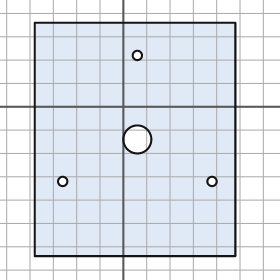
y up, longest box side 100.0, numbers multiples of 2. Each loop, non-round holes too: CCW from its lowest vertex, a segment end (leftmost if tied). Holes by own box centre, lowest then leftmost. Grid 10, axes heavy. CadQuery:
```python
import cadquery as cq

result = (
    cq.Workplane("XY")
    .moveTo(-38.0, -64.0)
    .lineTo(48.0, -64.0)
    .lineTo(48.0, 36.0)
    .lineTo(-38.0, 36.0)
    .close()
    .moveTo(-26.0, -32.0)
    .circle(2.0)
    .moveTo(38.0, -32.0)
    .circle(2.0)
    .moveTo(6.0, -14.0)
    .circle(6.0)
    .moveTo(6.0, 22.0)
    .circle(2.0)
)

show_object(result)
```